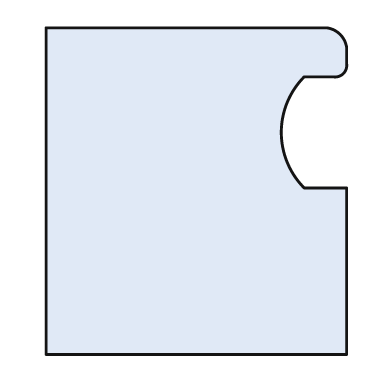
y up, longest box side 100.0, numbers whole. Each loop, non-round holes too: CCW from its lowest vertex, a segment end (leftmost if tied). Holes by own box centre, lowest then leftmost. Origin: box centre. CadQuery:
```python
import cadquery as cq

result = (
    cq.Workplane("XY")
    .moveTo(-46.0, -50.0)
    .lineTo(46.0, -50.0)
    .lineTo(46.0, 1.0)
    .lineTo(33.0, 1.0)
    .threePointArc((26.0, 18.0), (33.0, 35.0))
    .lineTo(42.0, 35.0)
    .threePointArc((45.0, 36.0), (46.0, 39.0))
    .lineTo(46.0, 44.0)
    .threePointArc((44.0, 48.0), (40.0, 50.0))
    .lineTo(-46.0, 50.0)
    .close()
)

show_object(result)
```